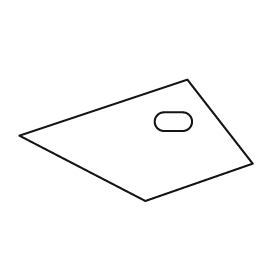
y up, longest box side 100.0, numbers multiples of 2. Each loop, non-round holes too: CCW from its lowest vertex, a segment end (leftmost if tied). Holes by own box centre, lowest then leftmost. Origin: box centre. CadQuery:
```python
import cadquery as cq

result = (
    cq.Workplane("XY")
    .moveTo(4.0, -26.0)
    .lineTo(50.0, -10.0)
    .lineTo(22.0, 26.0)
    .lineTo(-50.0, 2.0)
    .close()
    .moveTo(12.0, 4.0)
    .lineTo(20.0, 4.0)
    .threePointArc((24.0, 8.0), (20.0, 12.0))
    .lineTo(12.0, 12.0)
    .threePointArc((8.0, 8.0), (12.0, 4.0))
    .close()
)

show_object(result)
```